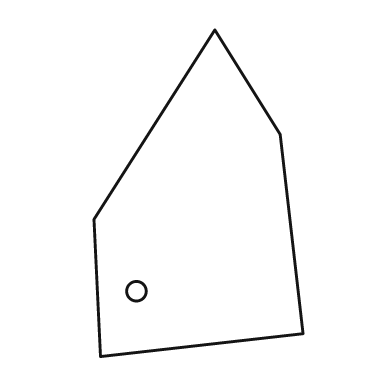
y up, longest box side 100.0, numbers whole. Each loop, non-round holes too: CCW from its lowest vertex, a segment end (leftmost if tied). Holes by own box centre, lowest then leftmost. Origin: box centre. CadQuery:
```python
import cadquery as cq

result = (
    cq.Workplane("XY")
    .moveTo(-30.0, -50.0)
    .lineTo(32.0, -43.0)
    .lineTo(25.0, 18.0)
    .lineTo(5.0, 50.0)
    .lineTo(-32.0, -8.0)
    .close()
    .moveTo(-19.0, -30.0)
    .circle(3.0)
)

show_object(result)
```